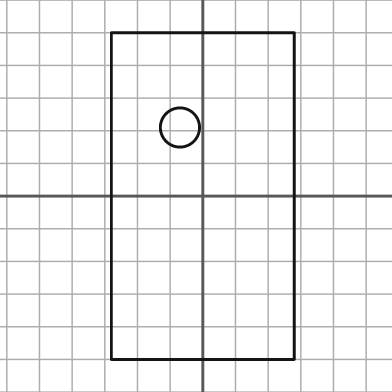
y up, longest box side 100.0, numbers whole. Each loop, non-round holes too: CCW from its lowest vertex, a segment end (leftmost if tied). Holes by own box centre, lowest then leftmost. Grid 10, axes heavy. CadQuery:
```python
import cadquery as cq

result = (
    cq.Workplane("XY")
    .moveTo(-28.0, -50.0)
    .lineTo(28.0, -50.0)
    .lineTo(28.0, 50.0)
    .lineTo(-28.0, 50.0)
    .close()
    .moveTo(-7.0, 21.0)
    .circle(6.0)
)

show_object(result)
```